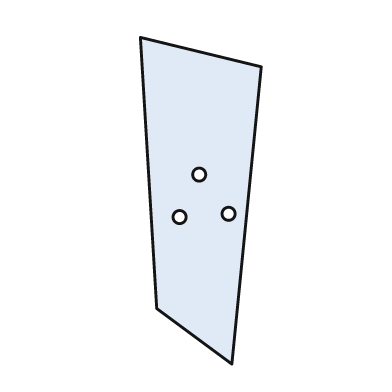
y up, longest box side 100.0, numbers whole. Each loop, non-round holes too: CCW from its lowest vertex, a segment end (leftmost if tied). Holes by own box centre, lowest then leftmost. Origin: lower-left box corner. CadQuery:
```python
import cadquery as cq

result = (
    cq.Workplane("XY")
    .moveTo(28.0, 0.0)
    .lineTo(37.0, 91.0)
    .lineTo(0.0, 100.0)
    .lineTo(5.0, 17.0)
    .close()
    .moveTo(12.0, 45.0)
    .circle(2.0)
    .moveTo(27.0, 46.0)
    .circle(2.0)
    .moveTo(18.0, 58.0)
    .circle(2.0)
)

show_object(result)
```